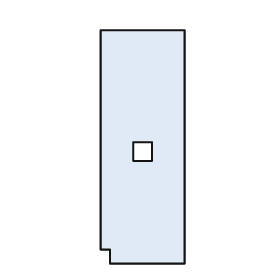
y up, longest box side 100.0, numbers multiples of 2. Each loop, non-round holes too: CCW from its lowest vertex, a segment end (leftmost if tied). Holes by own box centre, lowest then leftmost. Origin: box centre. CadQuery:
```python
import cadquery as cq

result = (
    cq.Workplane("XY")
    .moveTo(-14.0, -50.0)
    .lineTo(18.0, -50.0)
    .lineTo(18.0, 50.0)
    .lineTo(-18.0, 50.0)
    .lineTo(-18.0, -44.0)
    .lineTo(-14.0, -44.0)
    .close()
    .moveTo(-4.0, -6.0)
    .lineTo(4.0, -6.0)
    .lineTo(4.0, 2.0)
    .lineTo(-4.0, 2.0)
    .close()
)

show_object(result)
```